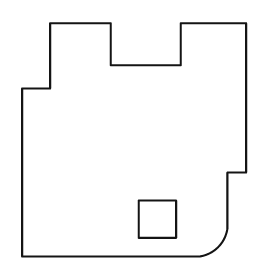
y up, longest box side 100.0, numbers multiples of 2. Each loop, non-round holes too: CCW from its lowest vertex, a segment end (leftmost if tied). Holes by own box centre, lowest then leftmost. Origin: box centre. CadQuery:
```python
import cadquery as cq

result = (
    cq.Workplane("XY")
    .moveTo(-48.0, -50.0)
    .lineTo(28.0, -50.0)
    .threePointArc((36.0, -46.0), (40.0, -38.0))
    .lineTo(40.0, -14.0)
    .lineTo(48.0, -14.0)
    .lineTo(48.0, 50.0)
    .lineTo(20.0, 50.0)
    .lineTo(20.0, 32.0)
    .lineTo(-10.0, 32.0)
    .lineTo(-10.0, 50.0)
    .lineTo(-36.0, 50.0)
    .lineTo(-36.0, 22.0)
    .lineTo(-48.0, 22.0)
    .close()
    .moveTo(2.0, -42.0)
    .lineTo(18.0, -42.0)
    .lineTo(18.0, -26.0)
    .lineTo(2.0, -26.0)
    .close()
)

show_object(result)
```